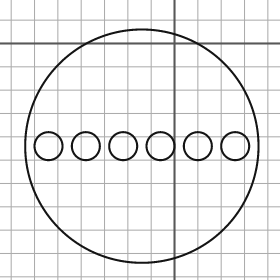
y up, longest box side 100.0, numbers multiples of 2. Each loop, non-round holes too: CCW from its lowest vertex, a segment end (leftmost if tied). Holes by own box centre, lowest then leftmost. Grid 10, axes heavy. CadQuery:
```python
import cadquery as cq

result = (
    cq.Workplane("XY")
    .moveTo(-14.0, -44.0)
    .circle(50.0)
    .moveTo(-54.0, -44.0)
    .circle(6.0)
    .moveTo(-38.0, -44.0)
    .circle(6.0)
    .moveTo(-22.0, -44.0)
    .circle(6.0)
    .moveTo(-6.0, -44.0)
    .circle(6.0)
    .moveTo(10.0, -44.0)
    .circle(6.0)
    .moveTo(26.0, -44.0)
    .circle(6.0)
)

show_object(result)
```